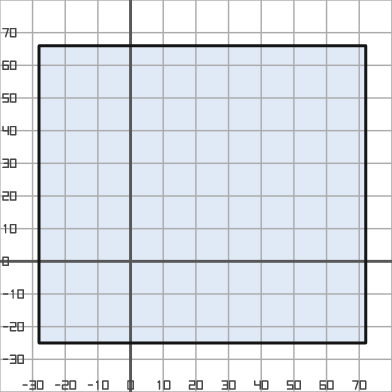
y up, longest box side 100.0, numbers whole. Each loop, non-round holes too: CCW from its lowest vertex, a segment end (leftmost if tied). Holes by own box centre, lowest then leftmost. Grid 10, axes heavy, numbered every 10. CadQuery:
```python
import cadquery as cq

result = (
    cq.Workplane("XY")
    .moveTo(-28.0, -25.0)
    .lineTo(72.0, -25.0)
    .lineTo(72.0, 66.0)
    .lineTo(-28.0, 66.0)
    .close()
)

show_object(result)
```